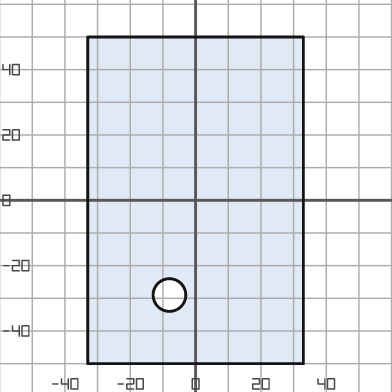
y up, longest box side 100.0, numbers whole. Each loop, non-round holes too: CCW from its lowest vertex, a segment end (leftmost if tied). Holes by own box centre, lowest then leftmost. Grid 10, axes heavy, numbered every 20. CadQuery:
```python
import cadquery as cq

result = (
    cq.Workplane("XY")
    .moveTo(-33.0, -50.0)
    .lineTo(33.0, -50.0)
    .lineTo(33.0, 50.0)
    .lineTo(-33.0, 50.0)
    .close()
    .moveTo(-8.0, -29.0)
    .circle(5.0)
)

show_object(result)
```